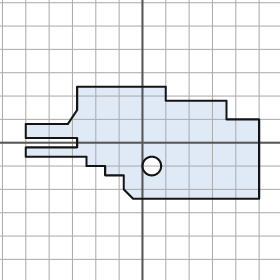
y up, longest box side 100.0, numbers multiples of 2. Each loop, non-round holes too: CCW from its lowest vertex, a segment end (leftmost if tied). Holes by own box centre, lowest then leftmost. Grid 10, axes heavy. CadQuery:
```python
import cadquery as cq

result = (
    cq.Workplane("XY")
    .moveTo(-4.0, -24.0)
    .lineTo(50.0, -24.0)
    .lineTo(50.0, 10.0)
    .lineTo(36.0, 10.0)
    .lineTo(36.0, 18.0)
    .lineTo(10.0, 18.0)
    .lineTo(10.0, 24.0)
    .lineTo(-28.0, 24.0)
    .lineTo(-28.0, 14.0)
    .lineTo(-32.0, 8.0)
    .lineTo(-50.0, 8.0)
    .lineTo(-50.0, 2.0)
    .lineTo(-28.0, 2.0)
    .lineTo(-28.0, -2.0)
    .lineTo(-50.0, -2.0)
    .lineTo(-50.0, -6.0)
    .lineTo(-24.0, -6.0)
    .lineTo(-24.0, -10.0)
    .lineTo(-16.0, -10.0)
    .lineTo(-16.0, -14.0)
    .lineTo(-8.0, -14.0)
    .lineTo(-8.0, -20.0)
    .close()
    .moveTo(4.0, -10.0)
    .circle(4.0)
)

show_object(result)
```